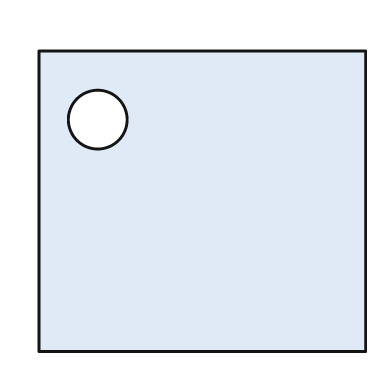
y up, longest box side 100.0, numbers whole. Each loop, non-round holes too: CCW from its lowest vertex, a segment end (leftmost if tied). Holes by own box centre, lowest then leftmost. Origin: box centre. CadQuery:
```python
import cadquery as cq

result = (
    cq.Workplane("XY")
    .moveTo(-50.0, -46.0)
    .lineTo(50.0, -46.0)
    .lineTo(50.0, 46.0)
    .lineTo(-50.0, 46.0)
    .close()
    .moveTo(-32.0, 25.0)
    .circle(9.0)
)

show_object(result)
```